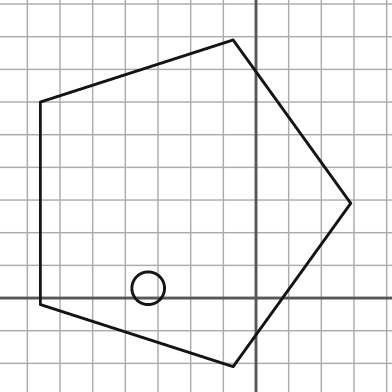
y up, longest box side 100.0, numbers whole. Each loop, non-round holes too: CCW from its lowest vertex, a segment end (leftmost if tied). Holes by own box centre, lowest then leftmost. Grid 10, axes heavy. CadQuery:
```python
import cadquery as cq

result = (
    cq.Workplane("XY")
    .moveTo(-7.0, -21.0)
    .lineTo(29.0, 29.0)
    .lineTo(-7.0, 79.0)
    .lineTo(-66.0, 60.0)
    .lineTo(-66.0, -2.0)
    .close()
    .moveTo(-33.0, 3.0)
    .circle(5.0)
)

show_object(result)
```